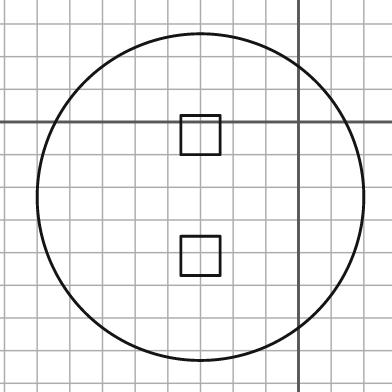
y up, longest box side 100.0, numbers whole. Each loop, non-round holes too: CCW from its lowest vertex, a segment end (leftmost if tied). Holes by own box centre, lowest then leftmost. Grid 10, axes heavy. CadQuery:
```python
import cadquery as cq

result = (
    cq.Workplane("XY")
    .moveTo(-30.0, -23.0)
    .circle(50.0)
    .moveTo(-36.0, -47.0)
    .lineTo(-24.0, -47.0)
    .lineTo(-24.0, -35.0)
    .lineTo(-36.0, -35.0)
    .close()
    .moveTo(-36.0, -10.0)
    .lineTo(-24.0, -10.0)
    .lineTo(-24.0, 2.0)
    .lineTo(-36.0, 2.0)
    .close()
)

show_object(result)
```